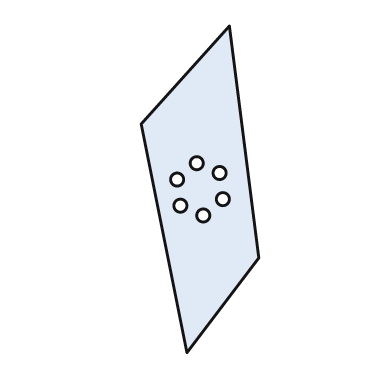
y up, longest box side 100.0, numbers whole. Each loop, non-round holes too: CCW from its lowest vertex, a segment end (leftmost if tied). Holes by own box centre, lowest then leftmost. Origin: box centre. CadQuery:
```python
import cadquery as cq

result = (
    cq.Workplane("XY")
    .moveTo(-4.0, -50.0)
    .lineTo(18.0, -21.0)
    .lineTo(9.0, 50.0)
    .lineTo(-18.0, 20.0)
    .close()
    .moveTo(1.0, -8.0)
    .circle(2.0)
    .moveTo(-6.0, -5.0)
    .circle(2.0)
    .moveTo(7.0, -3.0)
    .circle(2.0)
    .moveTo(-7.0, 3.0)
    .circle(2.0)
    .moveTo(6.0, 5.0)
    .circle(2.0)
    .moveTo(-1.0, 8.0)
    .circle(2.0)
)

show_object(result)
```